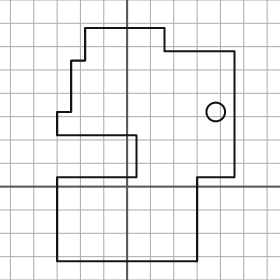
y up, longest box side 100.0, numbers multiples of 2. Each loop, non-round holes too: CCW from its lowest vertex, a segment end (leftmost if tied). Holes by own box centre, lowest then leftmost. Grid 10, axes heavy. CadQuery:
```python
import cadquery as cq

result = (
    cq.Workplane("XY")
    .moveTo(-30.0, -32.0)
    .lineTo(30.0, -32.0)
    .lineTo(30.0, 4.0)
    .lineTo(46.0, 4.0)
    .lineTo(46.0, 58.0)
    .lineTo(16.0, 58.0)
    .lineTo(16.0, 68.0)
    .lineTo(-18.0, 68.0)
    .lineTo(-18.0, 54.0)
    .lineTo(-24.0, 54.0)
    .lineTo(-24.0, 32.0)
    .lineTo(-30.0, 32.0)
    .lineTo(-30.0, 22.0)
    .lineTo(4.0, 22.0)
    .lineTo(4.0, 4.0)
    .lineTo(-30.0, 4.0)
    .close()
    .moveTo(38.0, 32.0)
    .circle(4.0)
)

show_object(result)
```